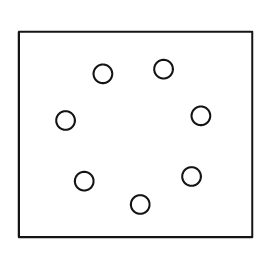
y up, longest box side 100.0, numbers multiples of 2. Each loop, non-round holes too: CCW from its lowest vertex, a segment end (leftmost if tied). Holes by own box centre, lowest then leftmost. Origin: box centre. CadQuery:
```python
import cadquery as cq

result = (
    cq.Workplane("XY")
    .moveTo(-50.0, -44.0)
    .lineTo(50.0, -44.0)
    .lineTo(50.0, 44.0)
    .lineTo(-50.0, 44.0)
    .close()
    .moveTo(2.0, -30.0)
    .circle(4.0)
    .moveTo(-22.0, -20.0)
    .circle(4.0)
    .moveTo(24.0, -18.0)
    .circle(4.0)
    .moveTo(-30.0, 6.0)
    .circle(4.0)
    .moveTo(28.0, 8.0)
    .circle(4.0)
    .moveTo(-14.0, 26.0)
    .circle(4.0)
    .moveTo(12.0, 28.0)
    .circle(4.0)
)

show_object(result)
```